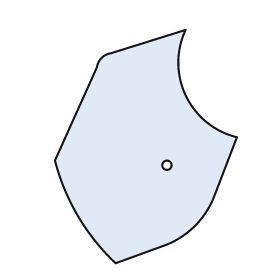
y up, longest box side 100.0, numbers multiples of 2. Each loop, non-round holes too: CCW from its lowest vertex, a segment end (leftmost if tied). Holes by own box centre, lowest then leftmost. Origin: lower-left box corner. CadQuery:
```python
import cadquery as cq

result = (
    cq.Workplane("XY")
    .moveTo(26.0, 0.0)
    .lineTo(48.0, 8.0)
    .threePointArc((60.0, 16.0), (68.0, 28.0))
    .lineTo(78.0, 54.0)
    .threePointArc((56.0, 72.0), (56.0, 100.0))
    .lineTo(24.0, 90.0)
    .threePointArc((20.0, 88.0), (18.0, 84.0))
    .lineTo(0.0, 44.0)
    .threePointArc((10.0, 20.0), (26.0, 0.0))
    .close()
    .moveTo(48.0, 42.0)
    .circle(2.0)
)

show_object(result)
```